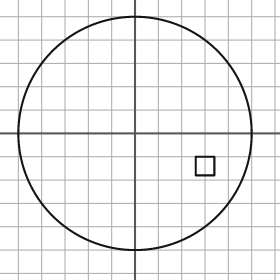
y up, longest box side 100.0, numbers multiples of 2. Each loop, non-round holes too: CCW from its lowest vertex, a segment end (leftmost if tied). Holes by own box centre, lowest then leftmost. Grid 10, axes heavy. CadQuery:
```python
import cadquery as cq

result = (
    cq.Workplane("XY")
    .moveTo(0.0, 0.0)
    .circle(50.0)
    .moveTo(26.0, -18.0)
    .lineTo(34.0, -18.0)
    .lineTo(34.0, -10.0)
    .lineTo(26.0, -10.0)
    .close()
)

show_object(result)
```